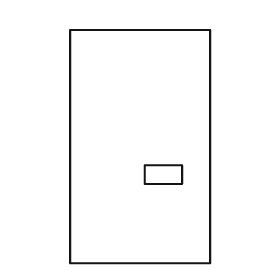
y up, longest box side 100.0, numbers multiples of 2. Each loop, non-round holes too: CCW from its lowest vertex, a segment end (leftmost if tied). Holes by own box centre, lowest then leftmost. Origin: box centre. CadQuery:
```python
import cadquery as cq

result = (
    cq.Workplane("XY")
    .moveTo(-30.0, -50.0)
    .lineTo(30.0, -50.0)
    .lineTo(30.0, 50.0)
    .lineTo(-30.0, 50.0)
    .close()
    .moveTo(2.0, -16.0)
    .lineTo(18.0, -16.0)
    .lineTo(18.0, -8.0)
    .lineTo(2.0, -8.0)
    .close()
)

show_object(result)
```